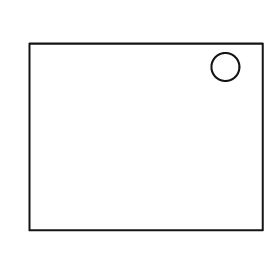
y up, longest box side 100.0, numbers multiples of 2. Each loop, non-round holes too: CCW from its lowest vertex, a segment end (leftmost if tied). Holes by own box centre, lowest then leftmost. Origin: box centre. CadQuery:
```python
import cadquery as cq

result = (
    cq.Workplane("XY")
    .moveTo(-50.0, -40.0)
    .lineTo(50.0, -40.0)
    .lineTo(50.0, 40.0)
    .lineTo(-50.0, 40.0)
    .close()
    .moveTo(34.0, 30.0)
    .circle(6.0)
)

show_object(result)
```